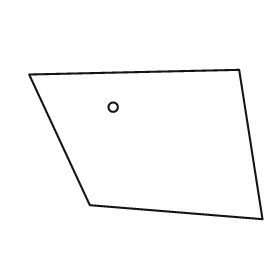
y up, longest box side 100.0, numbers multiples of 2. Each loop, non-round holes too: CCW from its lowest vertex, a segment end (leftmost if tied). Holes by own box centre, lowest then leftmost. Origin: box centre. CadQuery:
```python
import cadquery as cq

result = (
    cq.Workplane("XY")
    .moveTo(50.0, -32.0)
    .lineTo(40.0, 32.0)
    .lineTo(-50.0, 30.0)
    .lineTo(-24.0, -26.0)
    .close()
    .moveTo(-14.0, 16.0)
    .circle(2.0)
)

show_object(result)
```